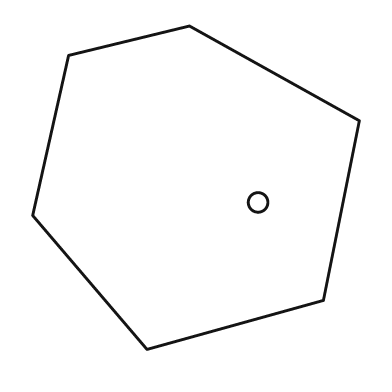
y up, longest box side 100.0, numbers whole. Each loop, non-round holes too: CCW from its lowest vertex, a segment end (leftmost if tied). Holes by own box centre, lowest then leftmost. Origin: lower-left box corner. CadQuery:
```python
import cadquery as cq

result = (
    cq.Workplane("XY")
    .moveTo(35.0, 0.0)
    .lineTo(89.0, 15.0)
    .lineTo(100.0, 70.0)
    .lineTo(48.0, 99.0)
    .lineTo(11.0, 90.0)
    .lineTo(0.0, 41.0)
    .close()
    .moveTo(69.0, 45.0)
    .circle(3.0)
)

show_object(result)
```